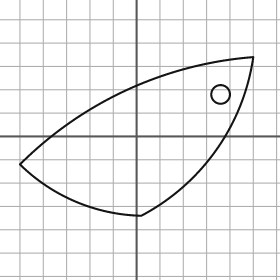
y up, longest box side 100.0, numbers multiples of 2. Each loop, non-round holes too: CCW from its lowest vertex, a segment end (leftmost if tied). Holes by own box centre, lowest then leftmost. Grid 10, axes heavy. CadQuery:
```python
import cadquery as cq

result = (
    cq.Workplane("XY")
    .moveTo(2.0, -34.0)
    .threePointArc((34.0, -6.0), (50.0, 34.0))
    .threePointArc((-4.0, 20.0), (-50.0, -12.0))
    .threePointArc((-26.0, -28.0), (2.0, -34.0))
    .close()
    .moveTo(36.0, 18.0)
    .circle(4.0)
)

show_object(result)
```